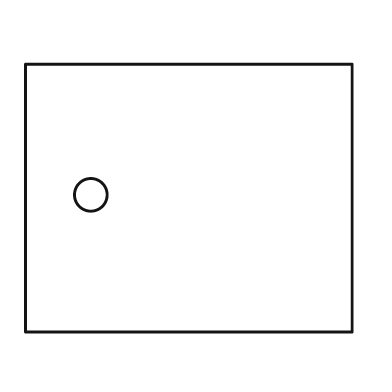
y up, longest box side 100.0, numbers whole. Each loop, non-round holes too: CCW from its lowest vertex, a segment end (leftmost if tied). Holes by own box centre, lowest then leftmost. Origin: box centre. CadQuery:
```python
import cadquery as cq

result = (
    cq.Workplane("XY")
    .moveTo(-50.0, -41.0)
    .lineTo(50.0, -41.0)
    .lineTo(50.0, 41.0)
    .lineTo(-50.0, 41.0)
    .close()
    .moveTo(-30.0, 1.0)
    .circle(5.0)
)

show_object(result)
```